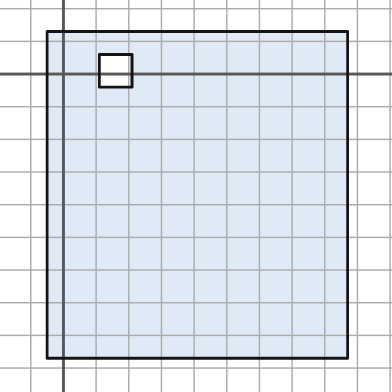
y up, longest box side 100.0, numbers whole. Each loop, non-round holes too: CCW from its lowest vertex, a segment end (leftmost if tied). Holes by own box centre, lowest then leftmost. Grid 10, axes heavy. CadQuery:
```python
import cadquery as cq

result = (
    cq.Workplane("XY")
    .moveTo(-5.0, -87.0)
    .lineTo(87.0, -87.0)
    .lineTo(87.0, 13.0)
    .lineTo(-5.0, 13.0)
    .close()
    .moveTo(11.0, -4.0)
    .lineTo(21.0, -4.0)
    .lineTo(21.0, 6.0)
    .lineTo(11.0, 6.0)
    .close()
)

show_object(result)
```